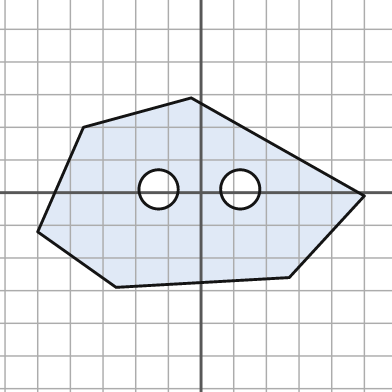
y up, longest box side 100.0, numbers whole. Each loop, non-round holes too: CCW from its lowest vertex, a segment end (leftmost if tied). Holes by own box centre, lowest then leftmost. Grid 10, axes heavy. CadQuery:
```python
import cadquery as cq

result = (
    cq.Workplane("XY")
    .moveTo(-26.0, -29.0)
    .lineTo(27.0, -26.0)
    .lineTo(50.0, -1.0)
    .lineTo(-3.0, 29.0)
    .lineTo(-36.0, 20.0)
    .lineTo(-50.0, -12.0)
    .close()
    .moveTo(-13.0, 1.0)
    .circle(6.0)
    .moveTo(12.0, 1.0)
    .circle(6.0)
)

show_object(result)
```